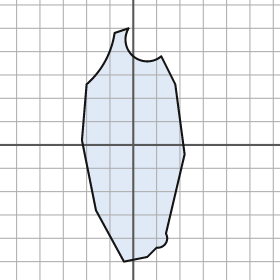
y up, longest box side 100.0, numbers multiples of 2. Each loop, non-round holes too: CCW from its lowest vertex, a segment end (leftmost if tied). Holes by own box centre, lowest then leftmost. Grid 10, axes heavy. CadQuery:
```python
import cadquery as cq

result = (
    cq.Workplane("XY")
    .moveTo(-4.0, -50.0)
    .lineTo(6.0, -48.0)
    .lineTo(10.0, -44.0)
    .threePointArc((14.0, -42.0), (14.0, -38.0))
    .lineTo(22.0, -4.0)
    .lineTo(18.0, 26.0)
    .lineTo(12.0, 38.0)
    .threePointArc((0.0, 38.0), (-2.0, 50.0))
    .lineTo(-8.0, 48.0)
    .threePointArc((-12.0, 36.0), (-20.0, 26.0))
    .lineTo(-22.0, 2.0)
    .lineTo(-16.0, -28.0)
    .close()
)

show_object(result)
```